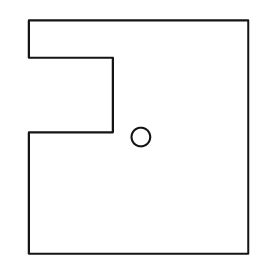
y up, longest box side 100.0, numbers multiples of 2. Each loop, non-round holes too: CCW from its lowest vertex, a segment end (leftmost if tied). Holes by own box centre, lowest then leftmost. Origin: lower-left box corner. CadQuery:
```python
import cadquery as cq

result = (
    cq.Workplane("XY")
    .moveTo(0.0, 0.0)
    .lineTo(94.0, 0.0)
    .lineTo(94.0, 100.0)
    .lineTo(0.0, 100.0)
    .lineTo(0.0, 84.0)
    .lineTo(36.0, 84.0)
    .lineTo(36.0, 52.0)
    .lineTo(0.0, 52.0)
    .close()
    .moveTo(48.0, 50.0)
    .circle(4.0)
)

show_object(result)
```